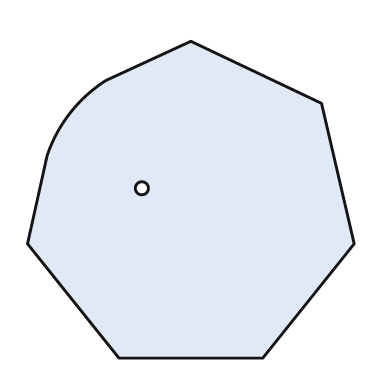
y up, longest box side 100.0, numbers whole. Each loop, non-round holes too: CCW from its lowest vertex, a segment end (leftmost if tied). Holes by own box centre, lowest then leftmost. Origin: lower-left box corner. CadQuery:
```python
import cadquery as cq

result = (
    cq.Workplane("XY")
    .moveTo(28.0, 0.0)
    .lineTo(72.0, 0.0)
    .lineTo(100.0, 35.0)
    .lineTo(90.0, 78.0)
    .lineTo(50.0, 97.0)
    .lineTo(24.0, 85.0)
    .threePointArc((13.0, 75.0), (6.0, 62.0))
    .lineTo(0.0, 35.0)
    .close()
    .moveTo(35.0, 52.0)
    .circle(2.0)
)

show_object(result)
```